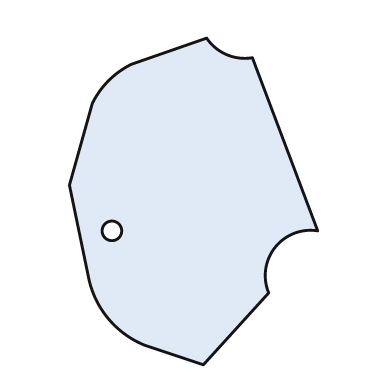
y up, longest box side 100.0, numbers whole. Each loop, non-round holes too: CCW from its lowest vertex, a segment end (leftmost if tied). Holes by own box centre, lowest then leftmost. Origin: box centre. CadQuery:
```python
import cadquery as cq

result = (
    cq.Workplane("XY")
    .moveTo(3.0, -50.0)
    .lineTo(23.0, -28.0)
    .threePointArc((25.0, -14.0), (38.0, -9.0))
    .lineTo(18.0, 44.0)
    .threePointArc((10.0, 45.0), (4.0, 50.0))
    .lineTo(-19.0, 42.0)
    .threePointArc((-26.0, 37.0), (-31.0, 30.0))
    .lineTo(-38.0, 5.0)
    .lineTo(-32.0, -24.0)
    .threePointArc((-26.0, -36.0), (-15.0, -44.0))
    .close()
    .moveTo(-25.0, -9.0)
    .circle(3.0)
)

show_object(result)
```